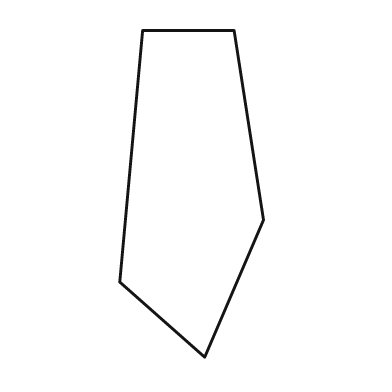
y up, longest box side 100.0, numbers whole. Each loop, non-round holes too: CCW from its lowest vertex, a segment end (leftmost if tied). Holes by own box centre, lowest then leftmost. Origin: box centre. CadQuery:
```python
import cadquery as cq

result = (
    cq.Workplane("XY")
    .moveTo(4.0, -50.0)
    .lineTo(22.0, -8.0)
    .lineTo(13.0, 50.0)
    .lineTo(-15.0, 50.0)
    .lineTo(-22.0, -27.0)
    .close()
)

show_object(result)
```